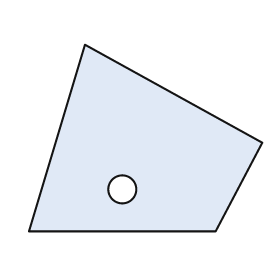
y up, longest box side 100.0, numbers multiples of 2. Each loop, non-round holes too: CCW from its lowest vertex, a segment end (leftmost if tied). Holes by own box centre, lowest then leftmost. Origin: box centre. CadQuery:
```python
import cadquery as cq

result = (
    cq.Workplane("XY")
    .moveTo(-50.0, -40.0)
    .lineTo(30.0, -40.0)
    .lineTo(50.0, -2.0)
    .lineTo(-26.0, 40.0)
    .close()
    .moveTo(-10.0, -22.0)
    .circle(6.0)
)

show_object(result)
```